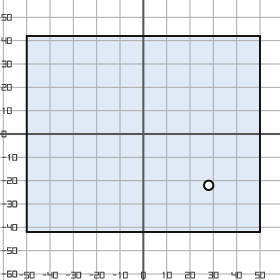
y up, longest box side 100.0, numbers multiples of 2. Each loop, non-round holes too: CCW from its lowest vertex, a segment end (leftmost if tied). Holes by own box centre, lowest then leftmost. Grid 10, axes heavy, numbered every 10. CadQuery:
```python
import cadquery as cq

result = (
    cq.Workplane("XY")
    .moveTo(-50.0, -42.0)
    .lineTo(50.0, -42.0)
    .lineTo(50.0, 42.0)
    .lineTo(-50.0, 42.0)
    .close()
    .moveTo(28.0, -22.0)
    .circle(2.0)
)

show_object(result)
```